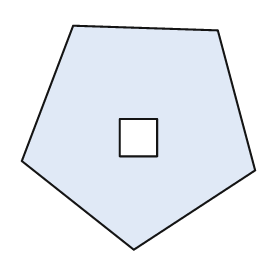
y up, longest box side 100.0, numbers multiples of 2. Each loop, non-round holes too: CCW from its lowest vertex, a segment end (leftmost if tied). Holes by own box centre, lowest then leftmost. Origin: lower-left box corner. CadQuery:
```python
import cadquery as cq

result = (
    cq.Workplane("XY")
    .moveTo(48.0, 0.0)
    .lineTo(100.0, 34.0)
    .lineTo(84.0, 94.0)
    .lineTo(22.0, 96.0)
    .lineTo(0.0, 38.0)
    .close()
    .moveTo(42.0, 40.0)
    .lineTo(58.0, 40.0)
    .lineTo(58.0, 56.0)
    .lineTo(42.0, 56.0)
    .close()
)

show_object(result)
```